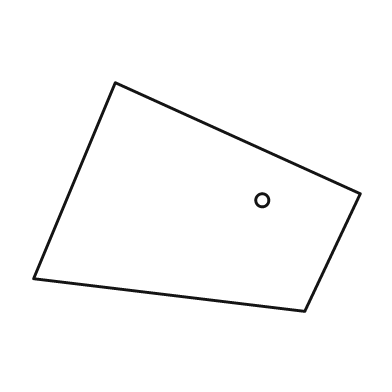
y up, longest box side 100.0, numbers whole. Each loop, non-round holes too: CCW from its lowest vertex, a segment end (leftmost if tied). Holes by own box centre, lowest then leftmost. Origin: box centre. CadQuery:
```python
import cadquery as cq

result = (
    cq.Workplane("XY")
    .moveTo(33.0, -35.0)
    .lineTo(50.0, 1.0)
    .lineTo(-25.0, 35.0)
    .lineTo(-50.0, -25.0)
    .close()
    .moveTo(20.0, -1.0)
    .circle(2.0)
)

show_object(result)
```